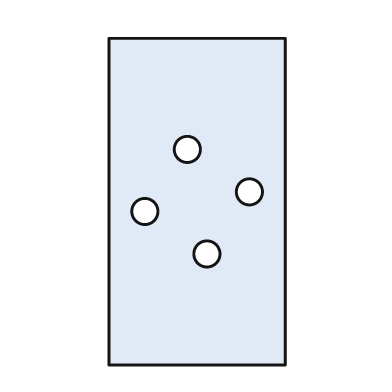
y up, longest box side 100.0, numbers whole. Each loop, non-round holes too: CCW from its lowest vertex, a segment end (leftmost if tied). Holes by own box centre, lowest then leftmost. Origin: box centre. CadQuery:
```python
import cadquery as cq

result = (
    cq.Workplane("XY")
    .moveTo(-27.0, -50.0)
    .lineTo(27.0, -50.0)
    .lineTo(27.0, 50.0)
    .lineTo(-27.0, 50.0)
    .close()
    .moveTo(3.0, -16.0)
    .circle(4.0)
    .moveTo(-16.0, -3.0)
    .circle(4.0)
    .moveTo(16.0, 3.0)
    .circle(4.0)
    .moveTo(-3.0, 16.0)
    .circle(4.0)
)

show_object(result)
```